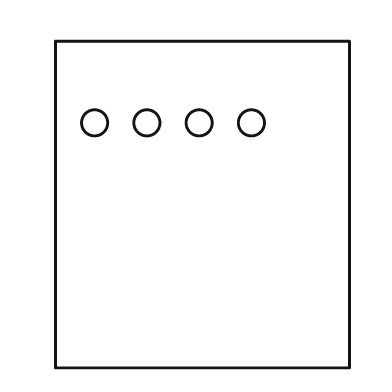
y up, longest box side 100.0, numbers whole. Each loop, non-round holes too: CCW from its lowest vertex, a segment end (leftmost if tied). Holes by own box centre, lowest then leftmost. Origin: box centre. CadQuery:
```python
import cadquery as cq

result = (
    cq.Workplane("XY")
    .moveTo(-45.0, -50.0)
    .lineTo(45.0, -50.0)
    .lineTo(45.0, 50.0)
    .lineTo(-45.0, 50.0)
    .close()
    .moveTo(-33.0, 25.0)
    .circle(4.0)
    .moveTo(-17.0, 25.0)
    .circle(4.0)
    .moveTo(-1.0, 25.0)
    .circle(4.0)
    .moveTo(15.0, 25.0)
    .circle(4.0)
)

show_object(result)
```